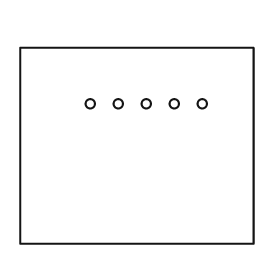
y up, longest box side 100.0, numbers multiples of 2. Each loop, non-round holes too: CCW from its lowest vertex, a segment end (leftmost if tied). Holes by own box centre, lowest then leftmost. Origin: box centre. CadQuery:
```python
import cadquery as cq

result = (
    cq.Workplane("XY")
    .moveTo(-50.0, -42.0)
    .lineTo(50.0, -42.0)
    .lineTo(50.0, 42.0)
    .lineTo(-50.0, 42.0)
    .close()
    .moveTo(-20.0, 18.0)
    .circle(2.0)
    .moveTo(-8.0, 18.0)
    .circle(2.0)
    .moveTo(4.0, 18.0)
    .circle(2.0)
    .moveTo(16.0, 18.0)
    .circle(2.0)
    .moveTo(28.0, 18.0)
    .circle(2.0)
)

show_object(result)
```